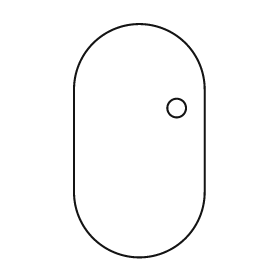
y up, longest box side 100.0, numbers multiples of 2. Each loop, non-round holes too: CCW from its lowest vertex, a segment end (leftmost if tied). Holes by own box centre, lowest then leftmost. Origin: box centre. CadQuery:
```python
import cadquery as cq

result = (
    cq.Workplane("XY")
    .moveTo(-28.0, -22.0)
    .threePointArc((0.0, -50.0), (28.0, -22.0))
    .lineTo(28.0, 22.0)
    .threePointArc((0.0, 50.0), (-28.0, 22.0))
    .close()
    .moveTo(16.0, 14.0)
    .circle(4.0)
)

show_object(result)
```